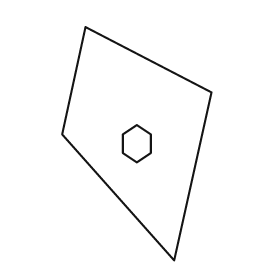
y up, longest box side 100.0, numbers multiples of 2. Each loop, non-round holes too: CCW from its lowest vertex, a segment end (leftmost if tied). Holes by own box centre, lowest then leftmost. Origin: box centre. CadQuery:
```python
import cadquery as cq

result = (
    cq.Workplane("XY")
    .moveTo(16.0, -50.0)
    .lineTo(32.0, 22.0)
    .lineTo(-22.0, 50.0)
    .lineTo(-32.0, 4.0)
    .close()
    .moveTo(0.0, -8.0)
    .lineTo(6.0, -4.0)
    .lineTo(6.0, 4.0)
    .lineTo(0.0, 8.0)
    .lineTo(-6.0, 4.0)
    .lineTo(-6.0, -4.0)
    .close()
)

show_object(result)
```